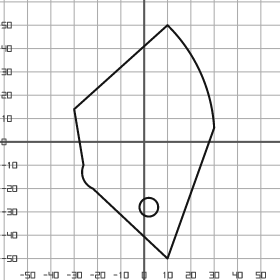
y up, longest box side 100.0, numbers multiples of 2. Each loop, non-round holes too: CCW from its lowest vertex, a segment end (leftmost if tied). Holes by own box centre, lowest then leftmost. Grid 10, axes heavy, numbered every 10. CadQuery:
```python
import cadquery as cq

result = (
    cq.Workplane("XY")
    .moveTo(10.0, -50.0)
    .lineTo(30.0, 6.0)
    .threePointArc((24.0, 30.0), (10.0, 50.0))
    .lineTo(-30.0, 14.0)
    .lineTo(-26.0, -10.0)
    .threePointArc((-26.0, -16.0), (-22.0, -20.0))
    .close()
    .moveTo(2.0, -28.0)
    .circle(4.0)
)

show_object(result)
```